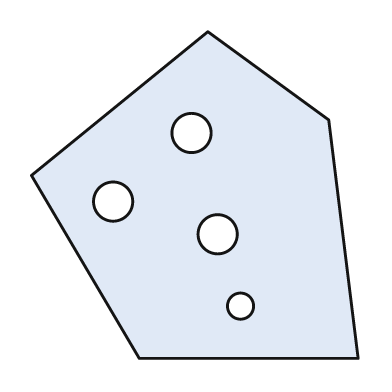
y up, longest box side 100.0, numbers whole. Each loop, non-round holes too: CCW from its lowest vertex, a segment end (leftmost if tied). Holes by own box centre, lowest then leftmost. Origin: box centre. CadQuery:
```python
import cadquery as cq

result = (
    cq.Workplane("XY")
    .moveTo(-17.0, -50.0)
    .lineTo(50.0, -50.0)
    .lineTo(41.0, 23.0)
    .lineTo(4.0, 50.0)
    .lineTo(-50.0, 6.0)
    .close()
    .moveTo(14.0, -34.0)
    .circle(4.0)
    .moveTo(7.0, -12.0)
    .circle(6.0)
    .moveTo(-25.0, -2.0)
    .circle(6.0)
    .moveTo(-1.0, 19.0)
    .circle(6.0)
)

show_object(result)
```